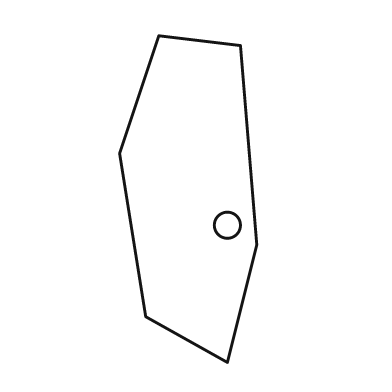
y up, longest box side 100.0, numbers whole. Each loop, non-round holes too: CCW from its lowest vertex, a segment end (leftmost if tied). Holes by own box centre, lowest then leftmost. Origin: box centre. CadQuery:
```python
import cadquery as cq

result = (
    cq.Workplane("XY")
    .moveTo(12.0, -50.0)
    .lineTo(21.0, -14.0)
    .lineTo(16.0, 47.0)
    .lineTo(-9.0, 50.0)
    .lineTo(-21.0, 14.0)
    .lineTo(-13.0, -36.0)
    .close()
    .moveTo(12.0, -8.0)
    .circle(4.0)
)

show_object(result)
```